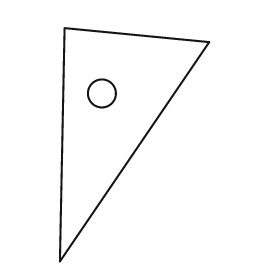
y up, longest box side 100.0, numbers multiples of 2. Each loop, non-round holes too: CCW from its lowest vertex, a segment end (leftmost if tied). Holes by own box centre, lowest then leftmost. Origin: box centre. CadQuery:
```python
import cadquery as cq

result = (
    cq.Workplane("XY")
    .moveTo(-32.0, -50.0)
    .lineTo(32.0, 44.0)
    .lineTo(-30.0, 50.0)
    .close()
    .moveTo(-14.0, 22.0)
    .circle(6.0)
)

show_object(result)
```